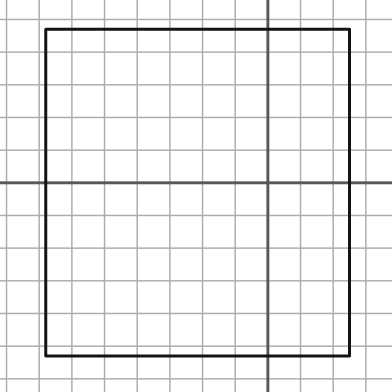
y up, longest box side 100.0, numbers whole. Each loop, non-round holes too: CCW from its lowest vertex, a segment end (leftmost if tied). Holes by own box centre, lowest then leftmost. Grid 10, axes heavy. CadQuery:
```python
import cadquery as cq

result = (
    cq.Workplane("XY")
    .moveTo(-68.0, -53.0)
    .lineTo(25.0, -53.0)
    .lineTo(25.0, 47.0)
    .lineTo(-68.0, 47.0)
    .close()
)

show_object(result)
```